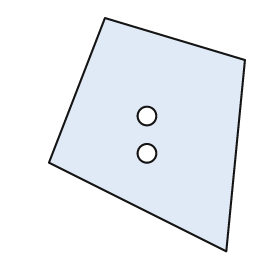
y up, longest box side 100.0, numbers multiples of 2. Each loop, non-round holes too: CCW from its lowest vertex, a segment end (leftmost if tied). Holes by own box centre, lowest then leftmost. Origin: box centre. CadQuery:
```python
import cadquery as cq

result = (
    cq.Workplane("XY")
    .moveTo(34.0, -50.0)
    .lineTo(42.0, 32.0)
    .lineTo(-18.0, 50.0)
    .lineTo(-42.0, -12.0)
    .close()
    .moveTo(0.0, -8.0)
    .circle(4.0)
    .moveTo(0.0, 8.0)
    .circle(4.0)
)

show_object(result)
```